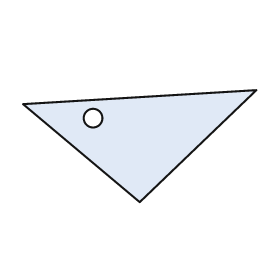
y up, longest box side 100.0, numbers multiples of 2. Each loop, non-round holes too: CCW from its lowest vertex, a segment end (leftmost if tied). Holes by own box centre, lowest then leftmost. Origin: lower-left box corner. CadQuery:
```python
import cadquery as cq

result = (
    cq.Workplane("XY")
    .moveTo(50.0, 0.0)
    .lineTo(100.0, 48.0)
    .lineTo(0.0, 42.0)
    .close()
    .moveTo(30.0, 36.0)
    .circle(4.0)
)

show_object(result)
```